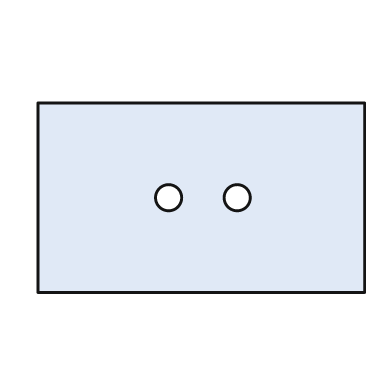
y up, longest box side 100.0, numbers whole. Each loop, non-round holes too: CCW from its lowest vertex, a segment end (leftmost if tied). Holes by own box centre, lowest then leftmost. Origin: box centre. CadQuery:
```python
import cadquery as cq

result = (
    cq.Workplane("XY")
    .moveTo(-50.0, -29.0)
    .lineTo(50.0, -29.0)
    .lineTo(50.0, 29.0)
    .lineTo(-50.0, 29.0)
    .close()
    .moveTo(-10.0, 0.0)
    .circle(4.0)
    .moveTo(11.0, 0.0)
    .circle(4.0)
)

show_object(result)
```